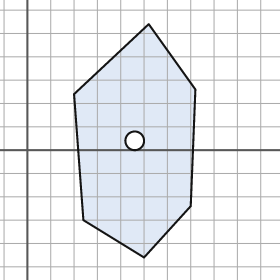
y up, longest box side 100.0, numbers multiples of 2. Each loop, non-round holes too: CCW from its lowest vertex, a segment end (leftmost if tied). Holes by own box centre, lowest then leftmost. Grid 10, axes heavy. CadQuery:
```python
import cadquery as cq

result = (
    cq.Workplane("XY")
    .moveTo(50.0, -46.0)
    .lineTo(70.0, -24.0)
    .lineTo(72.0, 26.0)
    .lineTo(52.0, 54.0)
    .lineTo(20.0, 24.0)
    .lineTo(24.0, -30.0)
    .close()
    .moveTo(46.0, 4.0)
    .circle(4.0)
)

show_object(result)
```